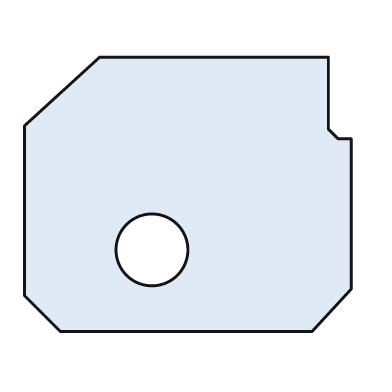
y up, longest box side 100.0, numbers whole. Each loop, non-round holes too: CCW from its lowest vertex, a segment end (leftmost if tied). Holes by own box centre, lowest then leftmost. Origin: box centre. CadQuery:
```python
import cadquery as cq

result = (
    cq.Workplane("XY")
    .moveTo(-39.0, -42.0)
    .lineTo(38.0, -42.0)
    .lineTo(50.0, -29.0)
    .lineTo(50.0, 17.0)
    .lineTo(46.0, 17.0)
    .lineTo(43.0, 20.0)
    .lineTo(43.0, 42.0)
    .lineTo(-27.0, 42.0)
    .lineTo(-50.0, 21.0)
    .lineTo(-50.0, -31.0)
    .close()
    .moveTo(-11.0, -17.0)
    .circle(11.0)
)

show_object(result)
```